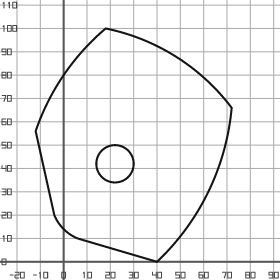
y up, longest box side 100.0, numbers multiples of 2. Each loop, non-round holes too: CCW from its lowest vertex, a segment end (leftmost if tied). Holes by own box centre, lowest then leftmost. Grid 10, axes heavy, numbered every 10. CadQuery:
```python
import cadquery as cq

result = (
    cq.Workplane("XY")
    .moveTo(40.0, 0.0)
    .threePointArc((62.0, 30.0), (72.0, 66.0))
    .threePointArc((48.0, 88.0), (18.0, 100.0))
    .threePointArc((0.0, 80.0), (-12.0, 56.0))
    .lineTo(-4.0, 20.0)
    .threePointArc((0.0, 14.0), (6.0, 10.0))
    .close()
    .moveTo(22.0, 42.0)
    .circle(8.0)
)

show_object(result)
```